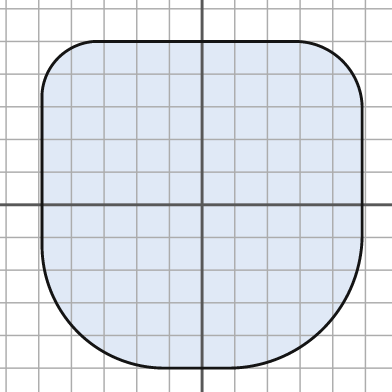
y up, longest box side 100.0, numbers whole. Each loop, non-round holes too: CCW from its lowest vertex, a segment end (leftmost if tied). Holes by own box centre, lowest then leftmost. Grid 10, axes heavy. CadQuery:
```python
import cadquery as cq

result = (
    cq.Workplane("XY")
    .moveTo(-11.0, -50.0)
    .lineTo(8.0, -50.0)
    .threePointArc((37.0, -38.0), (49.0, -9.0))
    .lineTo(49.0, 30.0)
    .threePointArc((43.0, 44.0), (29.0, 50.0))
    .lineTo(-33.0, 50.0)
    .threePointArc((-44.0, 45.0), (-49.0, 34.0))
    .lineTo(-49.0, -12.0)
    .threePointArc((-38.0, -39.0), (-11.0, -50.0))
    .close()
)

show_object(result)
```